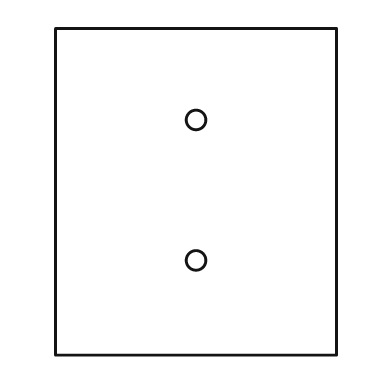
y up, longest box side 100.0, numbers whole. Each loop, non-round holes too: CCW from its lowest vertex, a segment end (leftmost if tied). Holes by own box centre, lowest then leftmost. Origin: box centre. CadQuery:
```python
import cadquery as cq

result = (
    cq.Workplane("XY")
    .moveTo(-43.0, -50.0)
    .lineTo(43.0, -50.0)
    .lineTo(43.0, 50.0)
    .lineTo(-43.0, 50.0)
    .close()
    .moveTo(0.0, -21.0)
    .circle(3.0)
    .moveTo(0.0, 22.0)
    .circle(3.0)
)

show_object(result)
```